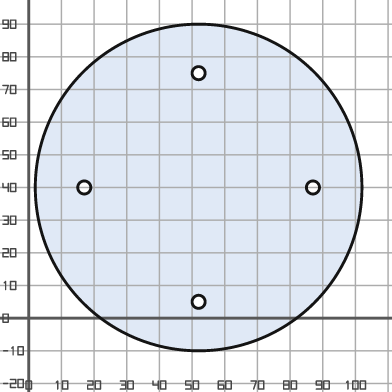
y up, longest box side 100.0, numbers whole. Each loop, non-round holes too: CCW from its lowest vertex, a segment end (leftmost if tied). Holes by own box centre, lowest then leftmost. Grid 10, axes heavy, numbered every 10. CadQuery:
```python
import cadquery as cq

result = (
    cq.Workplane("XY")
    .moveTo(52.0, 40.0)
    .circle(50.0)
    .moveTo(52.0, 5.0)
    .circle(2.0)
    .moveTo(17.0, 40.0)
    .circle(2.0)
    .moveTo(87.0, 40.0)
    .circle(2.0)
    .moveTo(52.0, 75.0)
    .circle(2.0)
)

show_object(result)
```